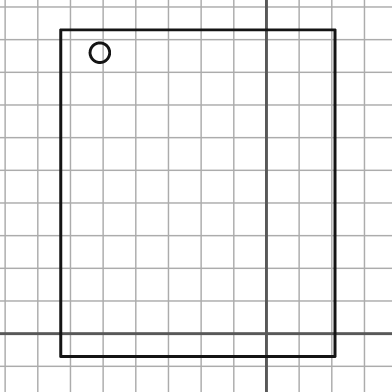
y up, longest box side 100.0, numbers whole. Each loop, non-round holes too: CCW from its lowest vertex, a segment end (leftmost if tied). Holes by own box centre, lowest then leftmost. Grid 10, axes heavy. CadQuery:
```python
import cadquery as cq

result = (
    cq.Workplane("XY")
    .moveTo(-63.0, -7.0)
    .lineTo(21.0, -7.0)
    .lineTo(21.0, 93.0)
    .lineTo(-63.0, 93.0)
    .close()
    .moveTo(-51.0, 86.0)
    .circle(3.0)
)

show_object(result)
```